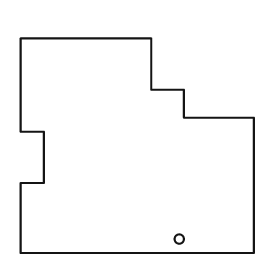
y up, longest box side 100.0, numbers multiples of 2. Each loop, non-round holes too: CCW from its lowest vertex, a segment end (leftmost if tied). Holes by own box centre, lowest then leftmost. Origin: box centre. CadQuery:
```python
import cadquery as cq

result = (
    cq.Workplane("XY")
    .moveTo(-50.0, -46.0)
    .lineTo(50.0, -46.0)
    .lineTo(50.0, 12.0)
    .lineTo(20.0, 12.0)
    .lineTo(20.0, 24.0)
    .lineTo(6.0, 24.0)
    .lineTo(6.0, 46.0)
    .lineTo(-50.0, 46.0)
    .lineTo(-50.0, 6.0)
    .lineTo(-40.0, 6.0)
    .lineTo(-40.0, -16.0)
    .lineTo(-50.0, -16.0)
    .close()
    .moveTo(18.0, -40.0)
    .circle(2.0)
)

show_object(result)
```